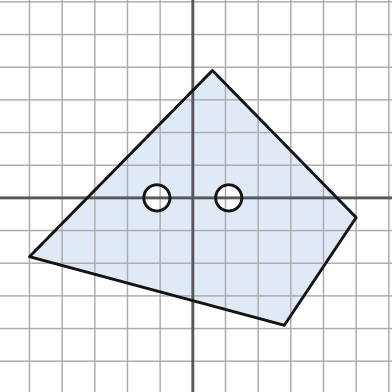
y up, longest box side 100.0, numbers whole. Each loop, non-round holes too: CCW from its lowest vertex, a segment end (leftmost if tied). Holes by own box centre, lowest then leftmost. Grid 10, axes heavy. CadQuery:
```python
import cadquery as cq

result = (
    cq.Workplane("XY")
    .moveTo(28.0, -39.0)
    .lineTo(50.0, -6.0)
    .lineTo(6.0, 39.0)
    .lineTo(-50.0, -18.0)
    .close()
    .moveTo(-11.0, 0.0)
    .circle(4.0)
    .moveTo(11.0, 0.0)
    .circle(4.0)
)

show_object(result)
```